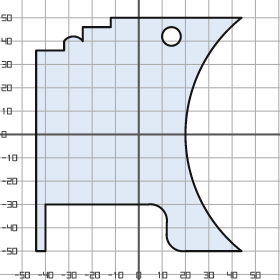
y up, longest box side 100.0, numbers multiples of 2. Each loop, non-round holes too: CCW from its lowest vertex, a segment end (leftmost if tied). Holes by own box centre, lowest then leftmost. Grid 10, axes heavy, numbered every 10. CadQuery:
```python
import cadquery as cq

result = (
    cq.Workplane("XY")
    .moveTo(-44.0, -50.0)
    .lineTo(-40.0, -50.0)
    .lineTo(-40.0, -30.0)
    .lineTo(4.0, -30.0)
    .threePointArc((10.0, -32.0), (12.0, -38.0))
    .lineTo(12.0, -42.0)
    .threePointArc((14.0, -48.0), (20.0, -50.0))
    .lineTo(44.0, -50.0)
    .threePointArc((20.0, 0.0), (44.0, 50.0))
    .lineTo(-12.0, 50.0)
    .lineTo(-12.0, 46.0)
    .lineTo(-24.0, 46.0)
    .lineTo(-24.0, 40.0)
    .threePointArc((-28.0, 42.0), (-32.0, 40.0))
    .lineTo(-32.0, 36.0)
    .lineTo(-44.0, 36.0)
    .close()
    .moveTo(14.0, 42.0)
    .circle(4.0)
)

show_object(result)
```